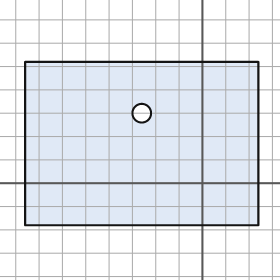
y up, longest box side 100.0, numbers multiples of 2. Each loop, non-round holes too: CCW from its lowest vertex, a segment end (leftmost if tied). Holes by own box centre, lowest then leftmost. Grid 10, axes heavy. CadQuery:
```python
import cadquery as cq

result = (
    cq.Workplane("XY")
    .moveTo(-76.0, -18.0)
    .lineTo(24.0, -18.0)
    .lineTo(24.0, 52.0)
    .lineTo(-76.0, 52.0)
    .close()
    .moveTo(-26.0, 30.0)
    .circle(4.0)
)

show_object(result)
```